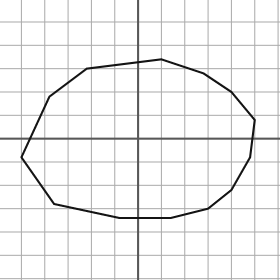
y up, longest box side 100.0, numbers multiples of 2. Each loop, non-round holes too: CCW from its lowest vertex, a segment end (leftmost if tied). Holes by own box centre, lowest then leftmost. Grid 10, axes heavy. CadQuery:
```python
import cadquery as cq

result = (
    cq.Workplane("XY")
    .moveTo(-8.0, -34.0)
    .lineTo(14.0, -34.0)
    .lineTo(30.0, -30.0)
    .lineTo(40.0, -22.0)
    .lineTo(48.0, -8.0)
    .lineTo(50.0, 8.0)
    .lineTo(40.0, 20.0)
    .lineTo(28.0, 28.0)
    .lineTo(10.0, 34.0)
    .lineTo(-22.0, 30.0)
    .lineTo(-38.0, 18.0)
    .lineTo(-50.0, -8.0)
    .lineTo(-36.0, -28.0)
    .close()
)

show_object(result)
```